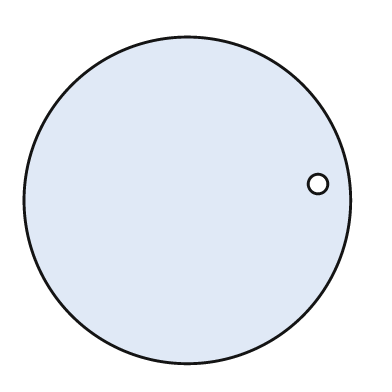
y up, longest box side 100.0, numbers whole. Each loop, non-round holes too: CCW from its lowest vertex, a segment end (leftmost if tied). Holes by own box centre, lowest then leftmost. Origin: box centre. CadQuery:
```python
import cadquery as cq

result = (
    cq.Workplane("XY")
    .moveTo(0.0, 0.0)
    .circle(50.0)
    .moveTo(40.0, 5.0)
    .circle(3.0)
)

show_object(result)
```